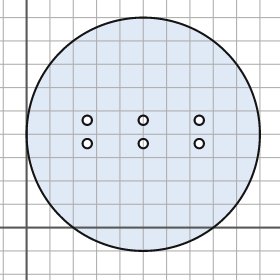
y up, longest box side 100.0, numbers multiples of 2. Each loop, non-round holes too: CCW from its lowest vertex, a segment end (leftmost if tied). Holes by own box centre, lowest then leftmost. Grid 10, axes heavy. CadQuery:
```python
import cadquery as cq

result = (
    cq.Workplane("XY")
    .moveTo(50.0, 40.0)
    .circle(50.0)
    .moveTo(26.0, 36.0)
    .circle(2.0)
    .moveTo(50.0, 36.0)
    .circle(2.0)
    .moveTo(74.0, 36.0)
    .circle(2.0)
    .moveTo(26.0, 46.0)
    .circle(2.0)
    .moveTo(50.0, 46.0)
    .circle(2.0)
    .moveTo(74.0, 46.0)
    .circle(2.0)
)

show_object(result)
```